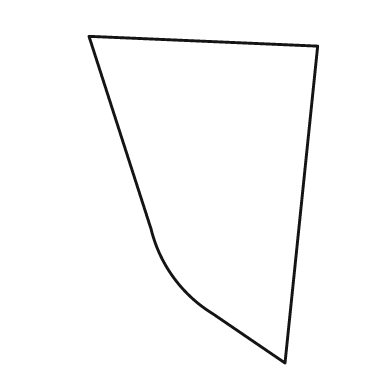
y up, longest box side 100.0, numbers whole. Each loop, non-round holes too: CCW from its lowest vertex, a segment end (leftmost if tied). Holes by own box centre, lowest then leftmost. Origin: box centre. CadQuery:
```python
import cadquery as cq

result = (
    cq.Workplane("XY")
    .moveTo(25.0, -50.0)
    .lineTo(35.0, 47.0)
    .lineTo(-35.0, 50.0)
    .lineTo(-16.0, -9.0)
    .threePointArc((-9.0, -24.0), (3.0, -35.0))
    .close()
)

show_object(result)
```